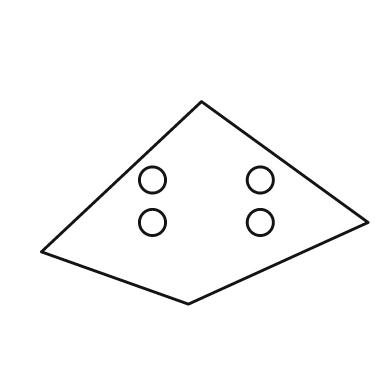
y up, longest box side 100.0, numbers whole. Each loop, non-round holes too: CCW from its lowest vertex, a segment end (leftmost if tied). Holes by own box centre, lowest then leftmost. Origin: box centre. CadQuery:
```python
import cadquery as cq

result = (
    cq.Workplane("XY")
    .moveTo(-5.0, -31.0)
    .lineTo(50.0, -6.0)
    .lineTo(-1.0, 31.0)
    .lineTo(-50.0, -15.0)
    .close()
    .moveTo(-16.0, -6.0)
    .circle(4.0)
    .moveTo(17.0, -6.0)
    .circle(4.0)
    .moveTo(-16.0, 7.0)
    .circle(4.0)
    .moveTo(17.0, 7.0)
    .circle(4.0)
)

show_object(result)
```